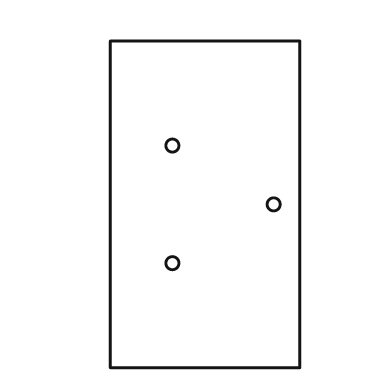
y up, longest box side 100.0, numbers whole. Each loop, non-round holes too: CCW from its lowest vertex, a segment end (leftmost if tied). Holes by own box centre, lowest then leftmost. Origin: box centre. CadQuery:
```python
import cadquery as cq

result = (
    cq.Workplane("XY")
    .moveTo(-29.0, -50.0)
    .lineTo(29.0, -50.0)
    .lineTo(29.0, 50.0)
    .lineTo(-29.0, 50.0)
    .close()
    .moveTo(-10.0, -18.0)
    .circle(2.0)
    .moveTo(21.0, 0.0)
    .circle(2.0)
    .moveTo(-10.0, 18.0)
    .circle(2.0)
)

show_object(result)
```